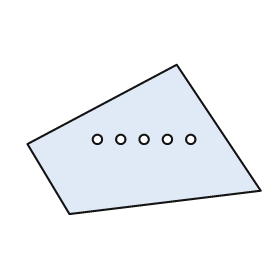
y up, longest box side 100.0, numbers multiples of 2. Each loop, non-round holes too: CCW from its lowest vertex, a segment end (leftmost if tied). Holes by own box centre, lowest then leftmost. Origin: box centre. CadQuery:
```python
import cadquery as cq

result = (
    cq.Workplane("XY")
    .moveTo(-32.0, -32.0)
    .lineTo(50.0, -22.0)
    .lineTo(14.0, 32.0)
    .lineTo(-50.0, -2.0)
    .close()
    .moveTo(-20.0, 0.0)
    .circle(2.0)
    .moveTo(-10.0, 0.0)
    .circle(2.0)
    .moveTo(0.0, 0.0)
    .circle(2.0)
    .moveTo(10.0, 0.0)
    .circle(2.0)
    .moveTo(20.0, 0.0)
    .circle(2.0)
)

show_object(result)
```